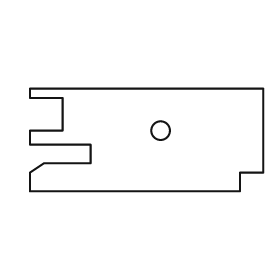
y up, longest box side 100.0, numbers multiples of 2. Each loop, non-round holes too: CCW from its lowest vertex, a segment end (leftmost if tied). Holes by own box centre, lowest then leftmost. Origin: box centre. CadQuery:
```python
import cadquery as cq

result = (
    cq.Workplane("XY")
    .moveTo(-50.0, -22.0)
    .lineTo(40.0, -22.0)
    .lineTo(40.0, -14.0)
    .lineTo(50.0, -14.0)
    .lineTo(50.0, 22.0)
    .lineTo(-50.0, 22.0)
    .lineTo(-50.0, 18.0)
    .lineTo(-36.0, 18.0)
    .lineTo(-36.0, 4.0)
    .lineTo(-50.0, 4.0)
    .lineTo(-50.0, -2.0)
    .lineTo(-24.0, -2.0)
    .lineTo(-24.0, -10.0)
    .lineTo(-44.0, -10.0)
    .lineTo(-50.0, -14.0)
    .close()
    .moveTo(6.0, 4.0)
    .circle(4.0)
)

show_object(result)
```